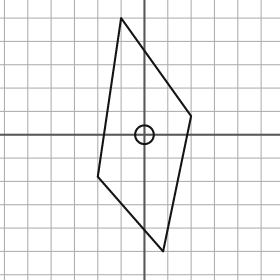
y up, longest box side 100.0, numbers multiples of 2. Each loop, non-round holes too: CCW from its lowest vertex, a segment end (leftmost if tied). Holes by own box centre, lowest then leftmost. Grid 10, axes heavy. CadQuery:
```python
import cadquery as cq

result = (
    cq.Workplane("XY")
    .moveTo(8.0, -50.0)
    .lineTo(20.0, 8.0)
    .lineTo(-10.0, 50.0)
    .lineTo(-20.0, -18.0)
    .close()
    .moveTo(0.0, 0.0)
    .circle(4.0)
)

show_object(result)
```